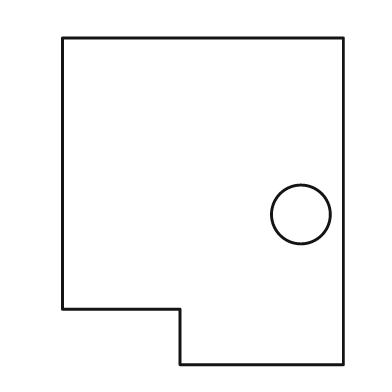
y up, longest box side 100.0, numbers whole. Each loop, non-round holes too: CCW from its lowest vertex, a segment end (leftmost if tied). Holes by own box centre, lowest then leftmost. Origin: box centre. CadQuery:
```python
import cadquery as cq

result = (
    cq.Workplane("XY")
    .moveTo(-7.0, -50.0)
    .lineTo(43.0, -50.0)
    .lineTo(43.0, 50.0)
    .lineTo(-43.0, 50.0)
    .lineTo(-43.0, -33.0)
    .lineTo(-7.0, -33.0)
    .close()
    .moveTo(30.0, -4.0)
    .circle(9.0)
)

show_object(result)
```